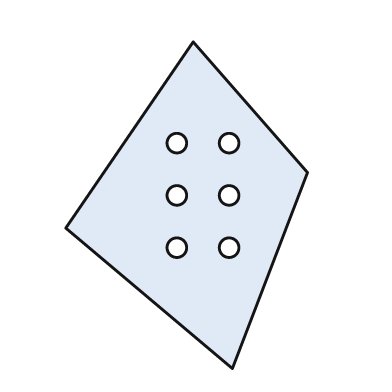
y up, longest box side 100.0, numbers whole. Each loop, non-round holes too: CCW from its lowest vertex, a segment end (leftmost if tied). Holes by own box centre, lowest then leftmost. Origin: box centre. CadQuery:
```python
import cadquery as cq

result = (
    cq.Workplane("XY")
    .moveTo(14.0, -50.0)
    .lineTo(37.0, 10.0)
    .lineTo(2.0, 50.0)
    .lineTo(-37.0, -7.0)
    .close()
    .moveTo(-3.0, -13.0)
    .circle(3.0)
    .moveTo(13.0, -13.0)
    .circle(3.0)
    .moveTo(-3.0, 3.0)
    .circle(3.0)
    .moveTo(13.0, 3.0)
    .circle(3.0)
    .moveTo(-3.0, 19.0)
    .circle(3.0)
    .moveTo(13.0, 19.0)
    .circle(3.0)
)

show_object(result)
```